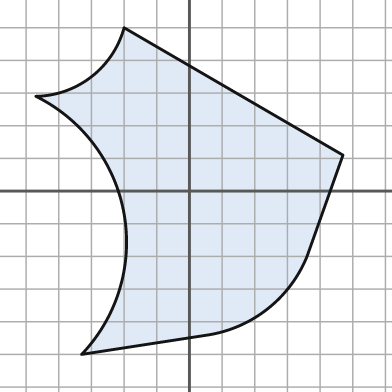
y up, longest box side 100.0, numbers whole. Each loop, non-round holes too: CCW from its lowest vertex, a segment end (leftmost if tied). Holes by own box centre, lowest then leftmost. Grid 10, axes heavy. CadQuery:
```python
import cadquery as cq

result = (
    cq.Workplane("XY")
    .moveTo(-33.0, -50.0)
    .lineTo(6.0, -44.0)
    .threePointArc((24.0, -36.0), (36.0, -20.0))
    .lineTo(47.0, 11.0)
    .lineTo(-20.0, 50.0)
    .threePointArc((-30.0, 35.0), (-47.0, 29.0))
    .threePointArc((-20.0, -7.0), (-33.0, -50.0))
    .close()
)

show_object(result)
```